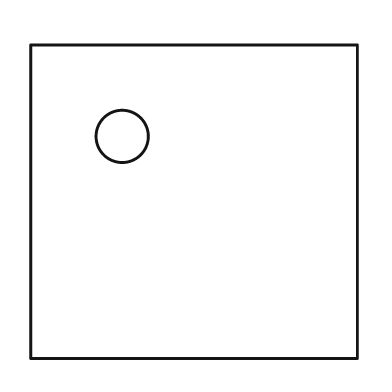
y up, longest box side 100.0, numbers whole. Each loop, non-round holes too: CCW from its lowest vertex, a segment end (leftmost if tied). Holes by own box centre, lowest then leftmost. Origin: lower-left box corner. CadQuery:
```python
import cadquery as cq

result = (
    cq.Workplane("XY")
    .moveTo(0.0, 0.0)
    .lineTo(100.0, 0.0)
    .lineTo(100.0, 96.0)
    .lineTo(0.0, 96.0)
    .close()
    .moveTo(28.0, 68.0)
    .circle(8.0)
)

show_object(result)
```